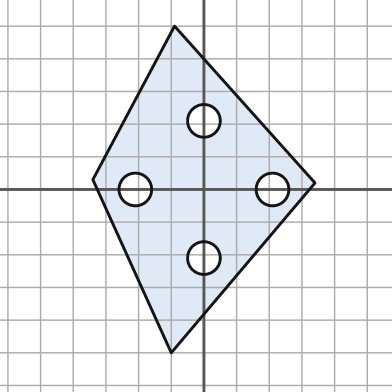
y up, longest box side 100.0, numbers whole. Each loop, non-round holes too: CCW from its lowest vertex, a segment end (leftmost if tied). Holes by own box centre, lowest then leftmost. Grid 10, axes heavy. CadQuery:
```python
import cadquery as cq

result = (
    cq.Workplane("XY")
    .moveTo(-10.0, -50.0)
    .lineTo(34.0, 2.0)
    .lineTo(-9.0, 50.0)
    .lineTo(-34.0, 3.0)
    .close()
    .moveTo(0.0, -21.0)
    .circle(5.0)
    .moveTo(-21.0, 0.0)
    .circle(5.0)
    .moveTo(21.0, 0.0)
    .circle(5.0)
    .moveTo(0.0, 21.0)
    .circle(5.0)
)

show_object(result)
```